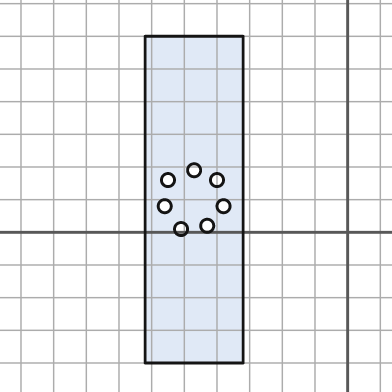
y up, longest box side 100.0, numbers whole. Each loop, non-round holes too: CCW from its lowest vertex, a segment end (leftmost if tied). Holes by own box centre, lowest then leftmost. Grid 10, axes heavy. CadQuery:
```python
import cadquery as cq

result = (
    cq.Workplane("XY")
    .moveTo(-62.0, -40.0)
    .lineTo(-32.0, -40.0)
    .lineTo(-32.0, 60.0)
    .lineTo(-62.0, 60.0)
    .close()
    .moveTo(-51.0, 1.0)
    .circle(2.0)
    .moveTo(-43.0, 2.0)
    .circle(2.0)
    .moveTo(-56.0, 8.0)
    .circle(2.0)
    .moveTo(-38.0, 8.0)
    .circle(2.0)
    .moveTo(-55.0, 16.0)
    .circle(2.0)
    .moveTo(-40.0, 16.0)
    .circle(2.0)
    .moveTo(-47.0, 19.0)
    .circle(2.0)
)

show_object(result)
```